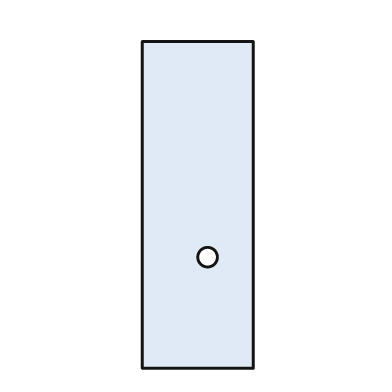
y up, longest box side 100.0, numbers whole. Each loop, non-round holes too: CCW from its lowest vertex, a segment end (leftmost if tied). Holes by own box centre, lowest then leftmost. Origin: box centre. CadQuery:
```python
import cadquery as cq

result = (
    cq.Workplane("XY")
    .moveTo(-17.0, -50.0)
    .lineTo(17.0, -50.0)
    .lineTo(17.0, 50.0)
    .lineTo(-17.0, 50.0)
    .close()
    .moveTo(3.0, -16.0)
    .circle(3.0)
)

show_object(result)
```